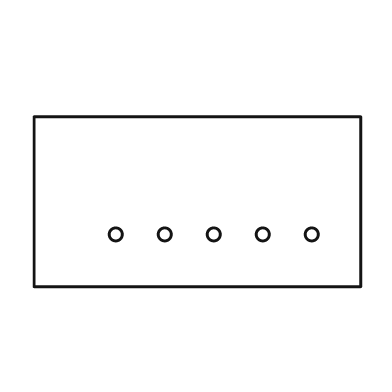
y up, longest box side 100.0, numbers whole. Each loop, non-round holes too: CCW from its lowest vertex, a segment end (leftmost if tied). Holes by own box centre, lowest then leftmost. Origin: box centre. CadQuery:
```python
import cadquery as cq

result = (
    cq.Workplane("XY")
    .moveTo(-50.0, -26.0)
    .lineTo(50.0, -26.0)
    .lineTo(50.0, 26.0)
    .lineTo(-50.0, 26.0)
    .close()
    .moveTo(-25.0, -10.0)
    .circle(2.0)
    .moveTo(-10.0, -10.0)
    .circle(2.0)
    .moveTo(5.0, -10.0)
    .circle(2.0)
    .moveTo(20.0, -10.0)
    .circle(2.0)
    .moveTo(35.0, -10.0)
    .circle(2.0)
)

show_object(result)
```